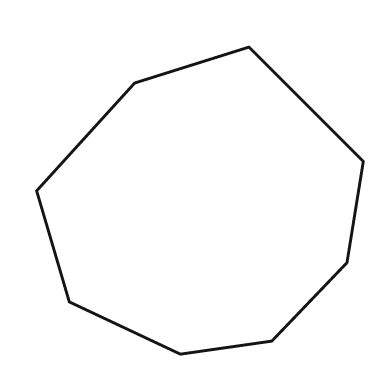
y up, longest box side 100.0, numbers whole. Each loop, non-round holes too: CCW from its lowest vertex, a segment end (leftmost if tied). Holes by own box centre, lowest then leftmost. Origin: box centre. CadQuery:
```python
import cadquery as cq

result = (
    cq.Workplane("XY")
    .moveTo(-6.0, -47.0)
    .lineTo(22.0, -43.0)
    .lineTo(45.0, -19.0)
    .lineTo(50.0, 12.0)
    .lineTo(15.0, 47.0)
    .lineTo(-20.0, 36.0)
    .lineTo(-50.0, 3.0)
    .lineTo(-40.0, -31.0)
    .close()
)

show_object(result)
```